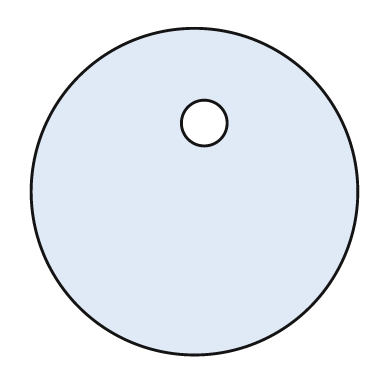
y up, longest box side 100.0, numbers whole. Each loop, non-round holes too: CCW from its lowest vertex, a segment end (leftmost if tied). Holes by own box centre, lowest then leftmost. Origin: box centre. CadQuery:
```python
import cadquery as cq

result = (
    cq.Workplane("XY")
    .moveTo(0.0, 0.0)
    .circle(50.0)
    .moveTo(3.0, 21.0)
    .circle(7.0)
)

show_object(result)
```